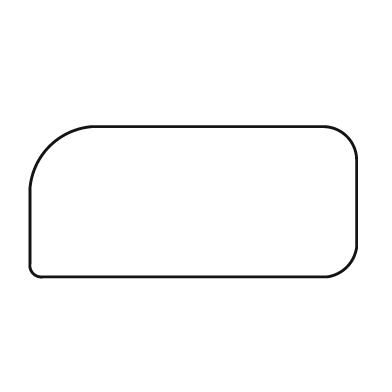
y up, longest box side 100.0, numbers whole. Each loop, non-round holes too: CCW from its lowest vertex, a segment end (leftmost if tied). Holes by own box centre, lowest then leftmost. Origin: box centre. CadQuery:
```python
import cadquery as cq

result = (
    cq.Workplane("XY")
    .moveTo(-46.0, -23.0)
    .lineTo(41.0, -23.0)
    .threePointArc((47.0, -20.0), (50.0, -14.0))
    .lineTo(50.0, 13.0)
    .threePointArc((47.0, 20.0), (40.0, 23.0))
    .lineTo(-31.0, 23.0)
    .threePointArc((-44.0, 17.0), (-50.0, 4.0))
    .lineTo(-50.0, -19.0)
    .threePointArc((-49.0, -22.0), (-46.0, -23.0))
    .close()
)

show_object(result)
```